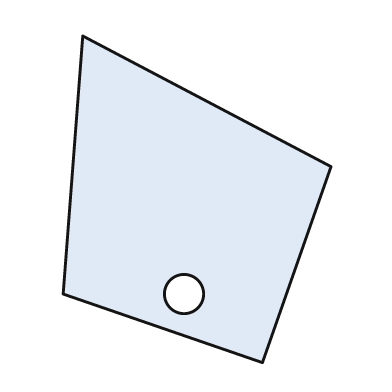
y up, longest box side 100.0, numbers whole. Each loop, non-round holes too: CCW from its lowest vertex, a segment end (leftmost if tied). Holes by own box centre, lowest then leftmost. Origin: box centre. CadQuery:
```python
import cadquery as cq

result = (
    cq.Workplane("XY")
    .moveTo(20.0, -50.0)
    .lineTo(41.0, 10.0)
    .lineTo(-35.0, 50.0)
    .lineTo(-41.0, -29.0)
    .close()
    .moveTo(-4.0, -29.0)
    .circle(6.0)
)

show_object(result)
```